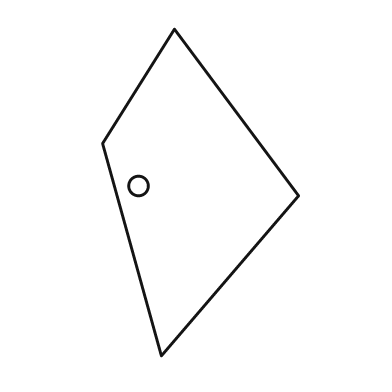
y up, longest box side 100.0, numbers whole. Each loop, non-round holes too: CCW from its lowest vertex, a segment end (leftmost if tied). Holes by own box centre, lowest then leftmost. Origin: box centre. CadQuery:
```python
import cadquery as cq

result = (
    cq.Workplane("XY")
    .moveTo(-12.0, -50.0)
    .lineTo(30.0, -1.0)
    .lineTo(-8.0, 50.0)
    .lineTo(-30.0, 15.0)
    .close()
    .moveTo(-19.0, 2.0)
    .circle(3.0)
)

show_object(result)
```